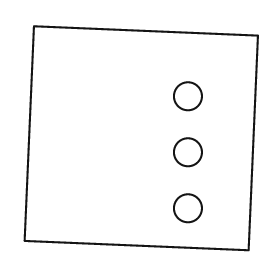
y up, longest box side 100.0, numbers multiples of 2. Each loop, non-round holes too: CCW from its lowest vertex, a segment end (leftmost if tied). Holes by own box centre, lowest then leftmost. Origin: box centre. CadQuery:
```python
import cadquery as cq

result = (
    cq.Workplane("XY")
    .moveTo(46.0, -48.0)
    .lineTo(50.0, 44.0)
    .lineTo(-46.0, 48.0)
    .lineTo(-50.0, -44.0)
    .close()
    .moveTo(20.0, -30.0)
    .circle(6.0)
    .moveTo(20.0, -6.0)
    .circle(6.0)
    .moveTo(20.0, 18.0)
    .circle(6.0)
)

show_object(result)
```